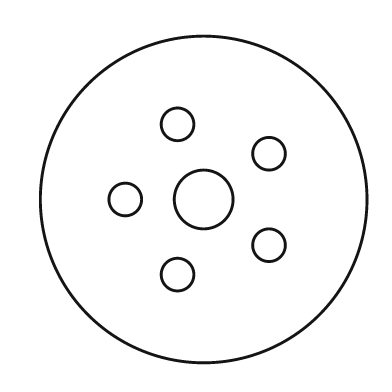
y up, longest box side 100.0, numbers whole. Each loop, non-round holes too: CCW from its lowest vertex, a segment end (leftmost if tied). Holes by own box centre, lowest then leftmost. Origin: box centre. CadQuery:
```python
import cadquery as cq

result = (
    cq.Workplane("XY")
    .moveTo(0.0, 0.0)
    .circle(50.0)
    .moveTo(-8.0, -23.0)
    .circle(5.0)
    .moveTo(20.0, -14.0)
    .circle(5.0)
    .moveTo(-24.0, 0.0)
    .circle(5.0)
    .moveTo(0.0, 0.0)
    .circle(9.0)
    .moveTo(20.0, 14.0)
    .circle(5.0)
    .moveTo(-8.0, 23.0)
    .circle(5.0)
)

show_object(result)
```